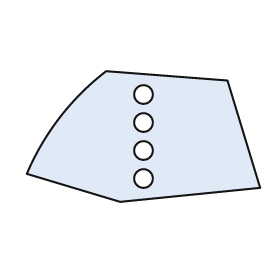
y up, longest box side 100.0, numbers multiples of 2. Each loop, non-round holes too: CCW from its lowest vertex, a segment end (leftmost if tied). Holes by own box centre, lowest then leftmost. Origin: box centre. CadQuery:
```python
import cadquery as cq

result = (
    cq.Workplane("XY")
    .moveTo(-10.0, -28.0)
    .lineTo(50.0, -22.0)
    .lineTo(36.0, 24.0)
    .lineTo(-16.0, 28.0)
    .threePointArc((-36.0, 8.0), (-50.0, -16.0))
    .close()
    .moveTo(0.0, -18.0)
    .circle(4.0)
    .moveTo(0.0, -6.0)
    .circle(4.0)
    .moveTo(0.0, 6.0)
    .circle(4.0)
    .moveTo(0.0, 18.0)
    .circle(4.0)
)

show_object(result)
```